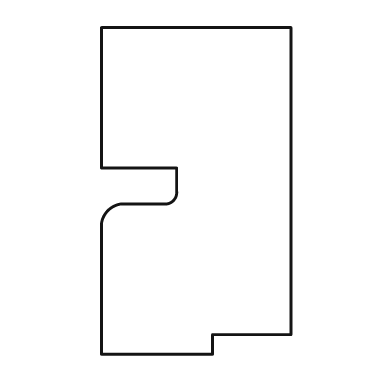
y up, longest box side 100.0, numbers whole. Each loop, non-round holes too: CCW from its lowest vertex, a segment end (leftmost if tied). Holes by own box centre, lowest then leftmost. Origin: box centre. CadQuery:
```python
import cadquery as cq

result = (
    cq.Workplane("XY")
    .moveTo(-29.0, -50.0)
    .lineTo(5.0, -50.0)
    .lineTo(5.0, -44.0)
    .lineTo(29.0, -44.0)
    .lineTo(29.0, 50.0)
    .lineTo(-29.0, 50.0)
    .lineTo(-29.0, 7.0)
    .lineTo(-6.0, 7.0)
    .lineTo(-6.0, 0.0)
    .threePointArc((-7.0, -3.0), (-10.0, -4.0))
    .lineTo(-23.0, -4.0)
    .threePointArc((-27.0, -6.0), (-29.0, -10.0))
    .close()
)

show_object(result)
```